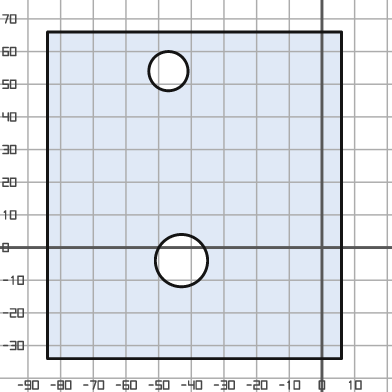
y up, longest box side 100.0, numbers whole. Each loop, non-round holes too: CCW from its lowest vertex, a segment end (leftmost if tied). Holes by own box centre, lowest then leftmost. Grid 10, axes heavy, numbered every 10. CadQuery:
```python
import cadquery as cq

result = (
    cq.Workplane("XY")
    .moveTo(-84.0, -34.0)
    .lineTo(6.0, -34.0)
    .lineTo(6.0, 66.0)
    .lineTo(-84.0, 66.0)
    .close()
    .moveTo(-43.0, -4.0)
    .circle(8.0)
    .moveTo(-47.0, 54.0)
    .circle(6.0)
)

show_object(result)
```